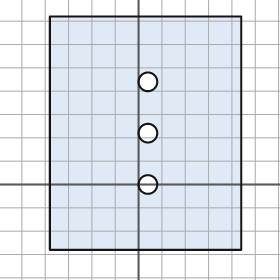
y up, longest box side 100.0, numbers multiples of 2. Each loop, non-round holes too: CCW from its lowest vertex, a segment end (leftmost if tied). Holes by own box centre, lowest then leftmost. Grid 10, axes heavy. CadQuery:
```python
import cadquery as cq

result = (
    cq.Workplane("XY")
    .moveTo(-38.0, -28.0)
    .lineTo(44.0, -28.0)
    .lineTo(44.0, 72.0)
    .lineTo(-38.0, 72.0)
    .close()
    .moveTo(4.0, 0.0)
    .circle(4.0)
    .moveTo(4.0, 22.0)
    .circle(4.0)
    .moveTo(4.0, 44.0)
    .circle(4.0)
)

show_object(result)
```